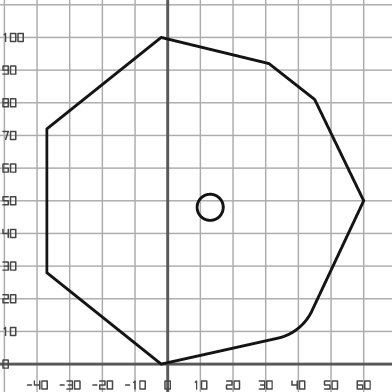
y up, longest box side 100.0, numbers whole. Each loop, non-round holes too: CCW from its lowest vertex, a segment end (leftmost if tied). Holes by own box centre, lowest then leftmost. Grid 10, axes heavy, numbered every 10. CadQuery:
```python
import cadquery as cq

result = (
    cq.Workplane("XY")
    .moveTo(-2.0, 0.0)
    .lineTo(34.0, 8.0)
    .threePointArc((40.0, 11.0), (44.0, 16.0))
    .lineTo(60.0, 50.0)
    .lineTo(45.0, 81.0)
    .lineTo(31.0, 92.0)
    .lineTo(-2.0, 100.0)
    .lineTo(-37.0, 72.0)
    .lineTo(-37.0, 28.0)
    .close()
    .moveTo(13.0, 48.0)
    .circle(4.0)
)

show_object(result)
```